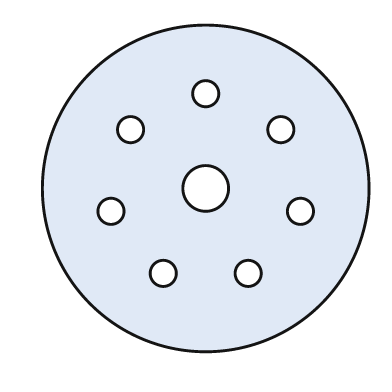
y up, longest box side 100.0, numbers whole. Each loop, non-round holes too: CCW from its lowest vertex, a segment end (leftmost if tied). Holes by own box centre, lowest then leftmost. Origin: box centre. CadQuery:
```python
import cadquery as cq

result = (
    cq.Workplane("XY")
    .moveTo(0.0, 0.0)
    .circle(50.0)
    .moveTo(-13.0, -26.0)
    .circle(4.0)
    .moveTo(13.0, -26.0)
    .circle(4.0)
    .moveTo(-29.0, -7.0)
    .circle(4.0)
    .moveTo(29.0, -7.0)
    .circle(4.0)
    .moveTo(0.0, 0.0)
    .circle(7.0)
    .moveTo(-23.0, 18.0)
    .circle(4.0)
    .moveTo(23.0, 18.0)
    .circle(4.0)
    .moveTo(0.0, 29.0)
    .circle(4.0)
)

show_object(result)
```